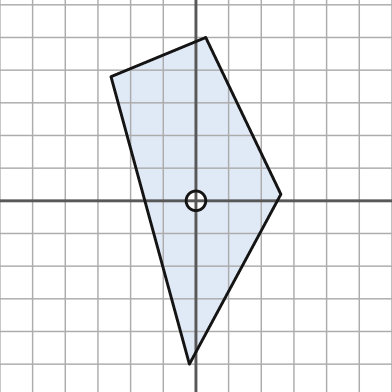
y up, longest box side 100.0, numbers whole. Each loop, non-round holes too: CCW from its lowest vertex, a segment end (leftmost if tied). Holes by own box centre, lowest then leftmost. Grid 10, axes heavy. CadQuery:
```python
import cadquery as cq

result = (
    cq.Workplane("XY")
    .moveTo(-2.0, -50.0)
    .lineTo(26.0, 2.0)
    .lineTo(3.0, 50.0)
    .lineTo(-26.0, 38.0)
    .close()
    .moveTo(0.0, 0.0)
    .circle(3.0)
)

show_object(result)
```